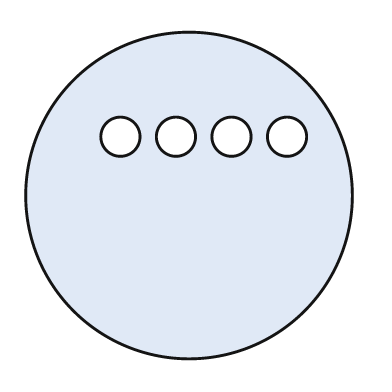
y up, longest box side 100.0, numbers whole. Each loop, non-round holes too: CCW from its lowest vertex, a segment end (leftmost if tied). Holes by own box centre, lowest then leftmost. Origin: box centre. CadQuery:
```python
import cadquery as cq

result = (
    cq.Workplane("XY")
    .moveTo(0.0, 0.0)
    .circle(50.0)
    .moveTo(-21.0, 18.0)
    .circle(6.0)
    .moveTo(-4.0, 18.0)
    .circle(6.0)
    .moveTo(13.0, 18.0)
    .circle(6.0)
    .moveTo(30.0, 18.0)
    .circle(6.0)
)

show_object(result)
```